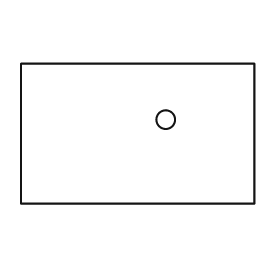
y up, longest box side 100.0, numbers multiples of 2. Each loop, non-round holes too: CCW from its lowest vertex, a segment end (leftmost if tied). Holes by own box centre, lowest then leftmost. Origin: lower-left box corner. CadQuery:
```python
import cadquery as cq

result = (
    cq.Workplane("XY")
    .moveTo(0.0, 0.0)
    .lineTo(100.0, 0.0)
    .lineTo(100.0, 60.0)
    .lineTo(0.0, 60.0)
    .close()
    .moveTo(62.0, 36.0)
    .circle(4.0)
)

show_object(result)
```